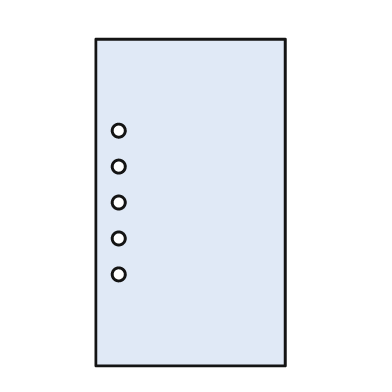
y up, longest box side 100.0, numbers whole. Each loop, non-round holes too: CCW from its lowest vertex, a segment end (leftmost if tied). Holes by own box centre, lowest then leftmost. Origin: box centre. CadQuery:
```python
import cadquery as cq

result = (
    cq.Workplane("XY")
    .moveTo(-29.0, -50.0)
    .lineTo(29.0, -50.0)
    .lineTo(29.0, 50.0)
    .lineTo(-29.0, 50.0)
    .close()
    .moveTo(-22.0, -22.0)
    .circle(2.0)
    .moveTo(-22.0, -11.0)
    .circle(2.0)
    .moveTo(-22.0, 0.0)
    .circle(2.0)
    .moveTo(-22.0, 11.0)
    .circle(2.0)
    .moveTo(-22.0, 22.0)
    .circle(2.0)
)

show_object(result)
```